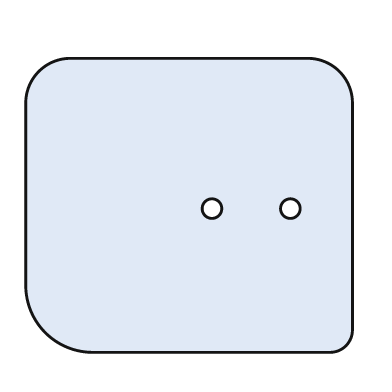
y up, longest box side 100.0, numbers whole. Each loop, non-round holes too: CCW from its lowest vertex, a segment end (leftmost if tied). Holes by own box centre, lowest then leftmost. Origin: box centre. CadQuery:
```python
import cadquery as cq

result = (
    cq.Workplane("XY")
    .moveTo(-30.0, -45.0)
    .lineTo(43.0, -45.0)
    .threePointArc((48.0, -43.0), (50.0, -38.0))
    .lineTo(50.0, 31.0)
    .threePointArc((46.0, 41.0), (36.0, 45.0))
    .lineTo(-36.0, 45.0)
    .threePointArc((-46.0, 41.0), (-50.0, 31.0))
    .lineTo(-50.0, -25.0)
    .threePointArc((-44.0, -39.0), (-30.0, -45.0))
    .close()
    .moveTo(7.0, -1.0)
    .circle(3.0)
    .moveTo(31.0, -1.0)
    .circle(3.0)
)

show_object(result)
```